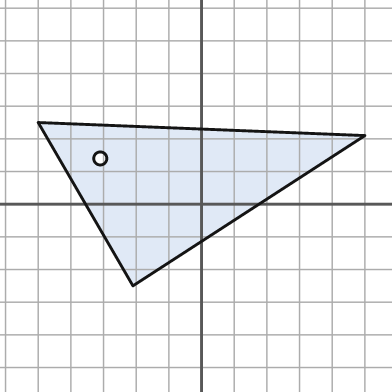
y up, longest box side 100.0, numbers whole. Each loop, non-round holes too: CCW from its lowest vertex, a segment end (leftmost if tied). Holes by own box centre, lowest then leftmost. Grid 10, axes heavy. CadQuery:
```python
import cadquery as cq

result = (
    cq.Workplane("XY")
    .moveTo(-21.0, -25.0)
    .lineTo(50.0, 21.0)
    .lineTo(-50.0, 25.0)
    .close()
    .moveTo(-31.0, 14.0)
    .circle(2.0)
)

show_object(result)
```